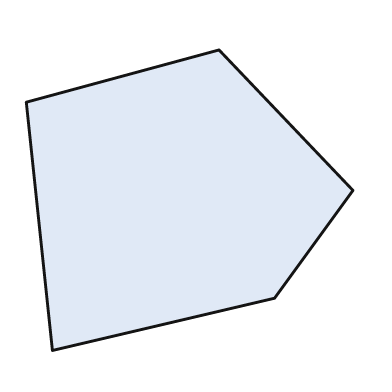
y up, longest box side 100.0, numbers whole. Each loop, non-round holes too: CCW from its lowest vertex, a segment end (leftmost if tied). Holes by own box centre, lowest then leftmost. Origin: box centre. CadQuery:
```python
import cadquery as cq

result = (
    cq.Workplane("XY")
    .moveTo(-42.0, -46.0)
    .lineTo(26.0, -30.0)
    .lineTo(50.0, 3.0)
    .lineTo(9.0, 46.0)
    .lineTo(-50.0, 30.0)
    .close()
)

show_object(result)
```